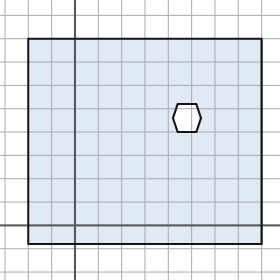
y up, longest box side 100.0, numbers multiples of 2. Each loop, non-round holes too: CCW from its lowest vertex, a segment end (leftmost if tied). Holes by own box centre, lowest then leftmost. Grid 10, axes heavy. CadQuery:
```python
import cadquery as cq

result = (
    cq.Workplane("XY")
    .moveTo(-20.0, -8.0)
    .lineTo(80.0, -8.0)
    .lineTo(80.0, 80.0)
    .lineTo(-20.0, 80.0)
    .close()
    .moveTo(44.0, 40.0)
    .lineTo(52.0, 40.0)
    .lineTo(54.0, 46.0)
    .lineTo(52.0, 52.0)
    .lineTo(44.0, 52.0)
    .lineTo(42.0, 46.0)
    .close()
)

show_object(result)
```